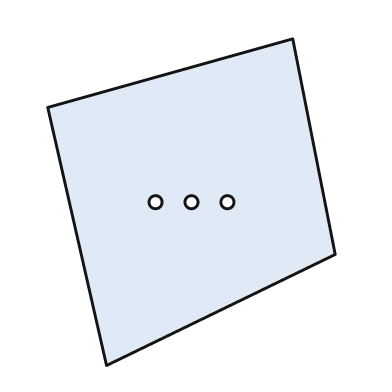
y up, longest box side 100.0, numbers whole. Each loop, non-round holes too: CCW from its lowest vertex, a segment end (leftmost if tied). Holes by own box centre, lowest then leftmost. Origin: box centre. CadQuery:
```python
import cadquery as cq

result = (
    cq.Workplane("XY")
    .moveTo(-26.0, -50.0)
    .lineTo(44.0, -16.0)
    .lineTo(31.0, 50.0)
    .lineTo(-44.0, 29.0)
    .close()
    .moveTo(-11.0, 0.0)
    .circle(2.0)
    .moveTo(0.0, 0.0)
    .circle(2.0)
    .moveTo(11.0, 0.0)
    .circle(2.0)
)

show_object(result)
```